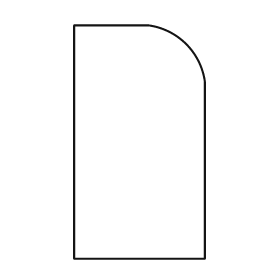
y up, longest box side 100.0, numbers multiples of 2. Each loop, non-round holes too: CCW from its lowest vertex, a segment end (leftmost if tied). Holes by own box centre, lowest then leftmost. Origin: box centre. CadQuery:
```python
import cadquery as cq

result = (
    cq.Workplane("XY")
    .moveTo(-28.0, -50.0)
    .lineTo(28.0, -50.0)
    .lineTo(28.0, 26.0)
    .threePointArc((20.0, 42.0), (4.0, 50.0))
    .lineTo(-28.0, 50.0)
    .close()
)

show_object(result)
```